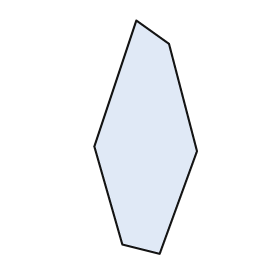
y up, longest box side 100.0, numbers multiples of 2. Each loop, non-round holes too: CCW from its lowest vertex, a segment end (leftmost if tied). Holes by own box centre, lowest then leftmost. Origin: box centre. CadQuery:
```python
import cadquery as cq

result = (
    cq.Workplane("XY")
    .moveTo(6.0, -50.0)
    .lineTo(22.0, -6.0)
    .lineTo(10.0, 40.0)
    .lineTo(-4.0, 50.0)
    .lineTo(-22.0, -4.0)
    .lineTo(-10.0, -46.0)
    .close()
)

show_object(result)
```